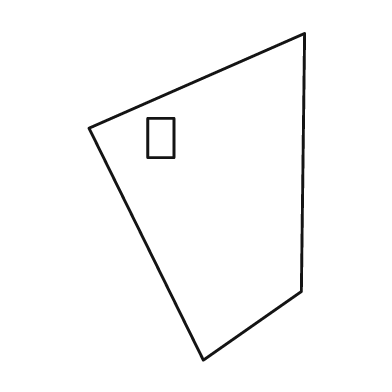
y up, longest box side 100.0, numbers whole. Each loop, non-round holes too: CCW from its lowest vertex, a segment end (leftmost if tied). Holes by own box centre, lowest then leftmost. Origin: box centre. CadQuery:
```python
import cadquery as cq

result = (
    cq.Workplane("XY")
    .moveTo(2.0, -50.0)
    .lineTo(32.0, -29.0)
    .lineTo(33.0, 50.0)
    .lineTo(-33.0, 21.0)
    .close()
    .moveTo(-15.0, 12.0)
    .lineTo(-7.0, 12.0)
    .lineTo(-7.0, 24.0)
    .lineTo(-15.0, 24.0)
    .close()
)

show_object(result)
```